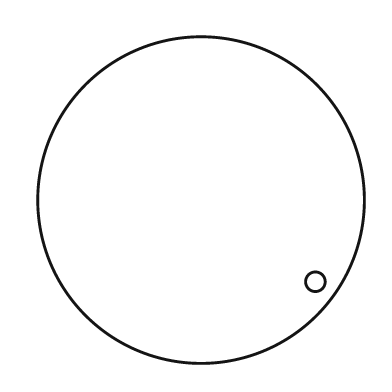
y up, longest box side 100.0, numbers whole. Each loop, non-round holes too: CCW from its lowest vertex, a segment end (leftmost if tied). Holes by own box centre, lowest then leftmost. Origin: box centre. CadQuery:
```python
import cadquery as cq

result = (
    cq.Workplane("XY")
    .moveTo(0.0, 0.0)
    .circle(50.0)
    .moveTo(35.0, -25.0)
    .circle(3.0)
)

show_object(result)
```